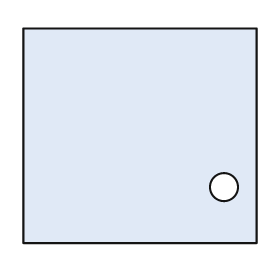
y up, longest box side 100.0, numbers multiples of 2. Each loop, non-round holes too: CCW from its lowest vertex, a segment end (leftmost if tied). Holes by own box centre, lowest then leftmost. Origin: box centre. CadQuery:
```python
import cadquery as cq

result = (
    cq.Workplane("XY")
    .moveTo(-50.0, -46.0)
    .lineTo(50.0, -46.0)
    .lineTo(50.0, 46.0)
    .lineTo(-50.0, 46.0)
    .close()
    .moveTo(36.0, -22.0)
    .circle(6.0)
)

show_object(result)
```